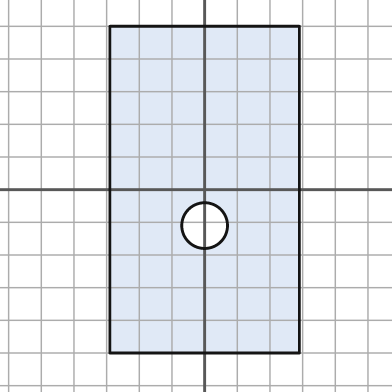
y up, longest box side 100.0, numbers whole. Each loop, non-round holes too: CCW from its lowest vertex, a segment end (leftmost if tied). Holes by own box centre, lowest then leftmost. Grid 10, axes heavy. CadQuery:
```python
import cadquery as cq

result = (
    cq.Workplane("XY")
    .moveTo(-29.0, -50.0)
    .lineTo(29.0, -50.0)
    .lineTo(29.0, 50.0)
    .lineTo(-29.0, 50.0)
    .close()
    .moveTo(0.0, -11.0)
    .circle(7.0)
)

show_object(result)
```